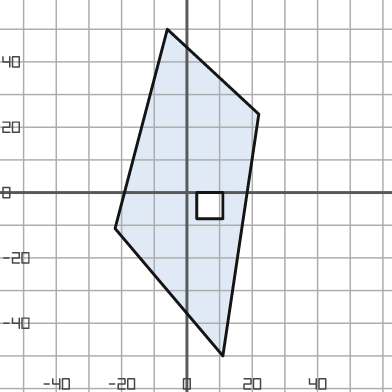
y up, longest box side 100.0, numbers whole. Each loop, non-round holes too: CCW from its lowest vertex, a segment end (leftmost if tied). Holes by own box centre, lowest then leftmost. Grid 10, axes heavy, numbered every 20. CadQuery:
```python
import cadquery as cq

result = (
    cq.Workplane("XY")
    .moveTo(11.0, -50.0)
    .lineTo(22.0, 24.0)
    .lineTo(-6.0, 50.0)
    .lineTo(-22.0, -11.0)
    .close()
    .moveTo(3.0, -8.0)
    .lineTo(11.0, -8.0)
    .lineTo(11.0, 0.0)
    .lineTo(3.0, 0.0)
    .close()
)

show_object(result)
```